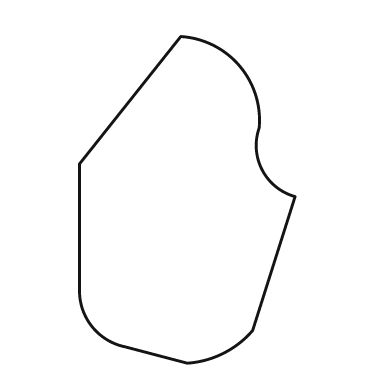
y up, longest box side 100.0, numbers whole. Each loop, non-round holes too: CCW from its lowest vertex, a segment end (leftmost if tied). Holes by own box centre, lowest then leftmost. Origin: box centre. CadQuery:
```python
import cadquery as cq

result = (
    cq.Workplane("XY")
    .moveTo(0.0, -50.0)
    .threePointArc((11.0, -47.0), (20.0, -40.0))
    .lineTo(33.0, 1.0)
    .threePointArc((23.0, 9.0), (22.0, 22.0))
    .threePointArc((16.0, 41.0), (-2.0, 50.0))
    .lineTo(-33.0, 11.0)
    .lineTo(-33.0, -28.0)
    .threePointArc((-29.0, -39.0), (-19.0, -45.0))
    .close()
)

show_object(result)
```